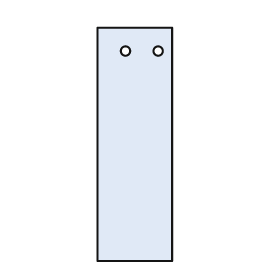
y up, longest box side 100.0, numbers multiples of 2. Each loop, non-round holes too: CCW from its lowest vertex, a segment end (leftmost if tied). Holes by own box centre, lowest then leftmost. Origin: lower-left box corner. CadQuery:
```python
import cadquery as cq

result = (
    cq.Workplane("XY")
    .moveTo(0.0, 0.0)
    .lineTo(32.0, 0.0)
    .lineTo(32.0, 100.0)
    .lineTo(0.0, 100.0)
    .close()
    .moveTo(12.0, 90.0)
    .circle(2.0)
    .moveTo(26.0, 90.0)
    .circle(2.0)
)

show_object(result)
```